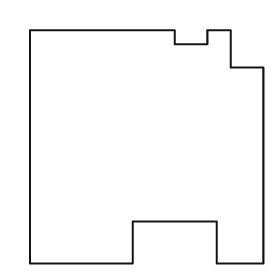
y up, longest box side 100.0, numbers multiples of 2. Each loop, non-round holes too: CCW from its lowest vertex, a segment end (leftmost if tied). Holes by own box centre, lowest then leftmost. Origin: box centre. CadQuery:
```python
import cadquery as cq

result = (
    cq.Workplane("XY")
    .moveTo(-50.0, -50.0)
    .lineTo(-6.0, -50.0)
    .lineTo(-6.0, -32.0)
    .lineTo(30.0, -32.0)
    .lineTo(30.0, -50.0)
    .lineTo(50.0, -50.0)
    .lineTo(50.0, 34.0)
    .lineTo(36.0, 34.0)
    .lineTo(36.0, 50.0)
    .lineTo(26.0, 50.0)
    .lineTo(26.0, 44.0)
    .lineTo(12.0, 44.0)
    .lineTo(12.0, 50.0)
    .lineTo(-50.0, 50.0)
    .close()
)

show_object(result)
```